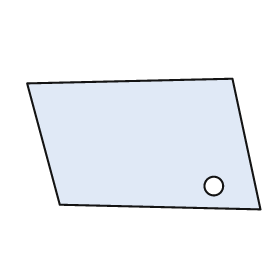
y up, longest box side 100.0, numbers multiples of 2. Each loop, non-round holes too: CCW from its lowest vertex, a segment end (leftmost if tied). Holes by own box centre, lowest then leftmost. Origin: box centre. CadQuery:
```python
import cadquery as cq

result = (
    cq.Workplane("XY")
    .moveTo(50.0, -28.0)
    .lineTo(38.0, 28.0)
    .lineTo(-50.0, 26.0)
    .lineTo(-36.0, -26.0)
    .close()
    .moveTo(30.0, -18.0)
    .circle(4.0)
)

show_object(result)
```